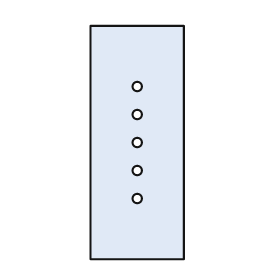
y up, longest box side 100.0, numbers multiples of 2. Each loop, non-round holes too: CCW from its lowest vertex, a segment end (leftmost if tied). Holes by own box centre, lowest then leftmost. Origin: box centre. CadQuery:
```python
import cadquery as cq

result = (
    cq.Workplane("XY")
    .moveTo(-20.0, -50.0)
    .lineTo(20.0, -50.0)
    .lineTo(20.0, 50.0)
    .lineTo(-20.0, 50.0)
    .close()
    .moveTo(0.0, -24.0)
    .circle(2.0)
    .moveTo(0.0, -12.0)
    .circle(2.0)
    .moveTo(0.0, 0.0)
    .circle(2.0)
    .moveTo(0.0, 12.0)
    .circle(2.0)
    .moveTo(0.0, 24.0)
    .circle(2.0)
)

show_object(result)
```